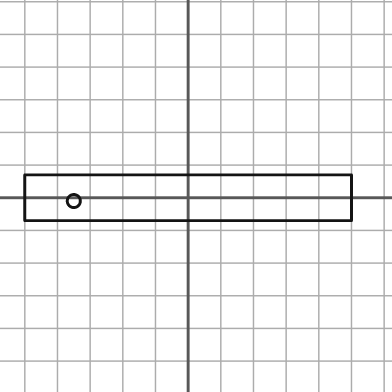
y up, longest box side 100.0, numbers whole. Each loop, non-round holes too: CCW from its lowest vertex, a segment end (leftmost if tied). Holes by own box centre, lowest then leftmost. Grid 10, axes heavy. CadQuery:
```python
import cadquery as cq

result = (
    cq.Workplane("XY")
    .moveTo(-50.0, -7.0)
    .lineTo(50.0, -7.0)
    .lineTo(50.0, 7.0)
    .lineTo(-50.0, 7.0)
    .close()
    .moveTo(-35.0, -1.0)
    .circle(2.0)
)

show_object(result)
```